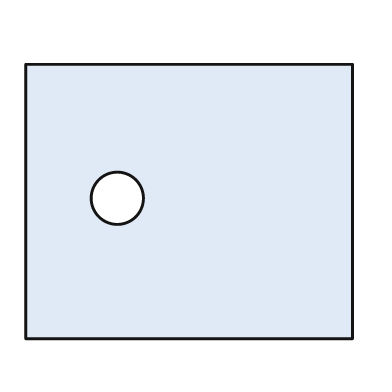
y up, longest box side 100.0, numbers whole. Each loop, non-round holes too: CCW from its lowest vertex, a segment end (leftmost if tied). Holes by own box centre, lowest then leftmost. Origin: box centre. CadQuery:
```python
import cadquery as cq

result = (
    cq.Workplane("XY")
    .moveTo(-50.0, -42.0)
    .lineTo(50.0, -42.0)
    .lineTo(50.0, 42.0)
    .lineTo(-50.0, 42.0)
    .close()
    .moveTo(-22.0, 1.0)
    .circle(8.0)
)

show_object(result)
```